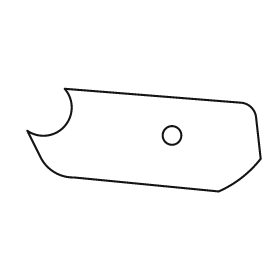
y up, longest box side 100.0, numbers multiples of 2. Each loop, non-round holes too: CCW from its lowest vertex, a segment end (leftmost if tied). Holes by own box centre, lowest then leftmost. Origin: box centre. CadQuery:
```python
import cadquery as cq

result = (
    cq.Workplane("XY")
    .moveTo(32.0, -22.0)
    .threePointArc((42.0, -16.0), (50.0, -8.0))
    .lineTo(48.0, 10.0)
    .threePointArc((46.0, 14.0), (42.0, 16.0))
    .lineTo(-34.0, 22.0)
    .threePointArc((-34.0, 6.0), (-50.0, 4.0))
    .lineTo(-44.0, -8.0)
    .threePointArc((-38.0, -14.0), (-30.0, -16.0))
    .close()
    .moveTo(12.0, 2.0)
    .circle(4.0)
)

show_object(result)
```